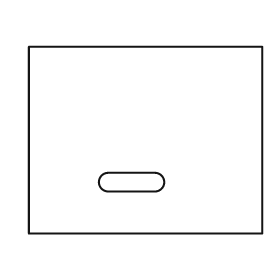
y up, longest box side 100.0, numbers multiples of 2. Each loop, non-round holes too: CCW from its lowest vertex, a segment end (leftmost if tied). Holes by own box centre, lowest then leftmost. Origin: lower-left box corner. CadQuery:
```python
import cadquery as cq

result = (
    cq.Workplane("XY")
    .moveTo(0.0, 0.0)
    .lineTo(100.0, 0.0)
    .lineTo(100.0, 80.0)
    .lineTo(0.0, 80.0)
    .close()
    .moveTo(34.0, 18.0)
    .lineTo(54.0, 18.0)
    .threePointArc((58.0, 22.0), (54.0, 26.0))
    .lineTo(34.0, 26.0)
    .threePointArc((30.0, 22.0), (34.0, 18.0))
    .close()
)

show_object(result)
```